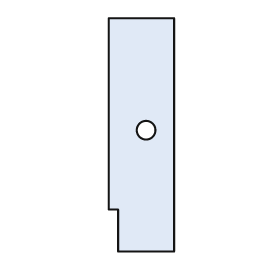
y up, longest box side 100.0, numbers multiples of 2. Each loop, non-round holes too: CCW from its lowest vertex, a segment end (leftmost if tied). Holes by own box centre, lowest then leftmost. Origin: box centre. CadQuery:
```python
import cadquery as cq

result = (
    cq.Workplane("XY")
    .moveTo(-10.0, -50.0)
    .lineTo(14.0, -50.0)
    .lineTo(14.0, 50.0)
    .lineTo(-14.0, 50.0)
    .lineTo(-14.0, -32.0)
    .lineTo(-10.0, -32.0)
    .close()
    .moveTo(2.0, 2.0)
    .circle(4.0)
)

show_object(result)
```